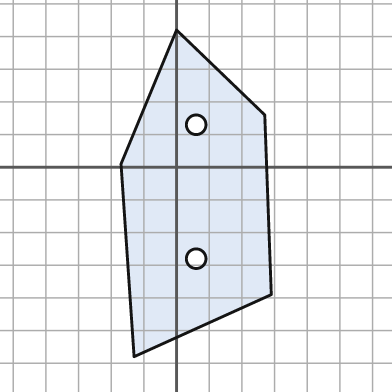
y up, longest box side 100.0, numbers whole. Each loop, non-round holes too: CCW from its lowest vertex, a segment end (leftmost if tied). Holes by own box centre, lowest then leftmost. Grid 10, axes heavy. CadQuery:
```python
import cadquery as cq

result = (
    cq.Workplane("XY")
    .moveTo(-13.0, -58.0)
    .lineTo(29.0, -39.0)
    .lineTo(27.0, 16.0)
    .lineTo(0.0, 42.0)
    .lineTo(-17.0, 1.0)
    .close()
    .moveTo(6.0, -28.0)
    .circle(3.0)
    .moveTo(6.0, 13.0)
    .circle(3.0)
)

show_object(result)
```